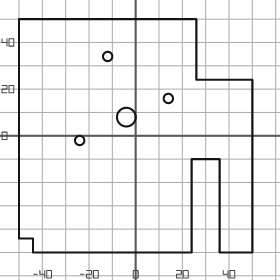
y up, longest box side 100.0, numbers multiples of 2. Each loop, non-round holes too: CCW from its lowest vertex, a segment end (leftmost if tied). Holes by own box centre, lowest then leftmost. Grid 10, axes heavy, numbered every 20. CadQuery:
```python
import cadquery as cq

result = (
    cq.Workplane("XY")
    .moveTo(-44.0, -50.0)
    .lineTo(24.0, -50.0)
    .lineTo(24.0, -10.0)
    .lineTo(36.0, -10.0)
    .lineTo(36.0, -50.0)
    .lineTo(50.0, -50.0)
    .lineTo(50.0, 24.0)
    .lineTo(26.0, 24.0)
    .lineTo(26.0, 50.0)
    .lineTo(-50.0, 50.0)
    .lineTo(-50.0, -44.0)
    .lineTo(-44.0, -44.0)
    .close()
    .moveTo(-24.0, -2.0)
    .circle(2.0)
    .moveTo(-4.0, 8.0)
    .circle(4.0)
    .moveTo(14.0, 16.0)
    .circle(2.0)
    .moveTo(-12.0, 34.0)
    .circle(2.0)
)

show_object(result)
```